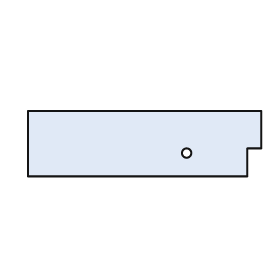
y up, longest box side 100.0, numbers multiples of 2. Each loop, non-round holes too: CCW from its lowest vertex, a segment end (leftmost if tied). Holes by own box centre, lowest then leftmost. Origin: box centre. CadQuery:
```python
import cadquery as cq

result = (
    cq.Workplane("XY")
    .moveTo(-50.0, -14.0)
    .lineTo(44.0, -14.0)
    .lineTo(44.0, -2.0)
    .lineTo(50.0, -2.0)
    .lineTo(50.0, 14.0)
    .lineTo(-50.0, 14.0)
    .close()
    .moveTo(18.0, -4.0)
    .circle(2.0)
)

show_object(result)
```